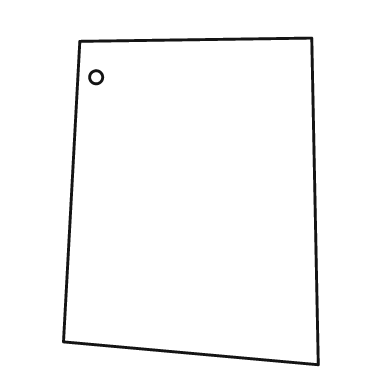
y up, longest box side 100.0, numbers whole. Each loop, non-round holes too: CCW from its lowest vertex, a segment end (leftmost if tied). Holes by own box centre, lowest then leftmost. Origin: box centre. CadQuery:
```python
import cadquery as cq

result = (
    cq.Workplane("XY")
    .moveTo(39.0, -50.0)
    .lineTo(37.0, 50.0)
    .lineTo(-34.0, 49.0)
    .lineTo(-39.0, -43.0)
    .close()
    .moveTo(-29.0, 38.0)
    .circle(2.0)
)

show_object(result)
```